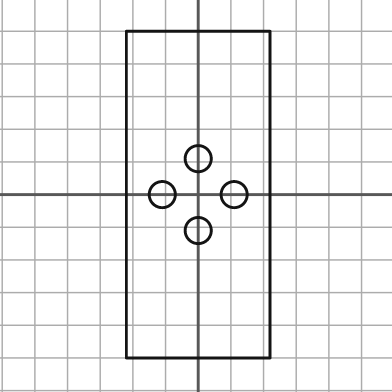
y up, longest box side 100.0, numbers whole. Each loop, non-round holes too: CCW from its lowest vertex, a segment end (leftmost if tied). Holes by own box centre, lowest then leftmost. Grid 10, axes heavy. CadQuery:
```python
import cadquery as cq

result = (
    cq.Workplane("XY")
    .moveTo(-22.0, -50.0)
    .lineTo(22.0, -50.0)
    .lineTo(22.0, 50.0)
    .lineTo(-22.0, 50.0)
    .close()
    .moveTo(0.0, -11.0)
    .circle(4.0)
    .moveTo(-11.0, 0.0)
    .circle(4.0)
    .moveTo(11.0, 0.0)
    .circle(4.0)
    .moveTo(0.0, 11.0)
    .circle(4.0)
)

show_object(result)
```